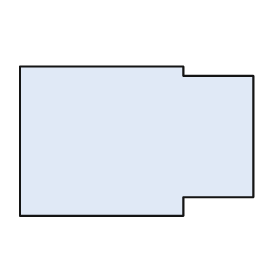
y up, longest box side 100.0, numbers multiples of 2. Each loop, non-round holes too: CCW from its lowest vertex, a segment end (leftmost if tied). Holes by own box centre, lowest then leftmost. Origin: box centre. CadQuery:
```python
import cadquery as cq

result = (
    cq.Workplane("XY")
    .moveTo(-50.0, -32.0)
    .lineTo(20.0, -32.0)
    .lineTo(20.0, -24.0)
    .lineTo(50.0, -24.0)
    .lineTo(50.0, 28.0)
    .lineTo(20.0, 28.0)
    .lineTo(20.0, 32.0)
    .lineTo(-50.0, 32.0)
    .close()
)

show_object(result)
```